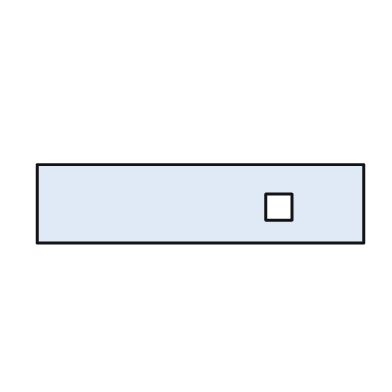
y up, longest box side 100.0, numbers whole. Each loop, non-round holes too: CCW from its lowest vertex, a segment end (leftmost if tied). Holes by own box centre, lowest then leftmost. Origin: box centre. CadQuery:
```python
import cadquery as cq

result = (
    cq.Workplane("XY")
    .moveTo(-50.0, -12.0)
    .lineTo(50.0, -12.0)
    .lineTo(50.0, 12.0)
    .lineTo(-50.0, 12.0)
    .close()
    .moveTo(20.0, -5.0)
    .lineTo(28.0, -5.0)
    .lineTo(28.0, 3.0)
    .lineTo(20.0, 3.0)
    .close()
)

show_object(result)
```